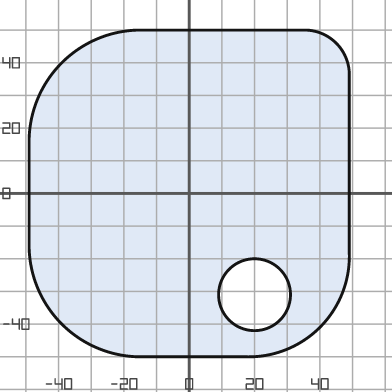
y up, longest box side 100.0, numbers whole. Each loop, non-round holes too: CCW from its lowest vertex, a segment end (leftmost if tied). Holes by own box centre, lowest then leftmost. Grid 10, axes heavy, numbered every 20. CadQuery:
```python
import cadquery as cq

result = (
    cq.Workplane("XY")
    .moveTo(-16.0, -50.0)
    .lineTo(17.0, -50.0)
    .threePointArc((40.0, -41.0), (49.0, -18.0))
    .lineTo(49.0, 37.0)
    .threePointArc((45.0, 46.0), (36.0, 50.0))
    .lineTo(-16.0, 50.0)
    .threePointArc((-39.0, 40.0), (-49.0, 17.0))
    .lineTo(-49.0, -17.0)
    .threePointArc((-39.0, -40.0), (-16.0, -50.0))
    .close()
    .moveTo(20.0, -31.0)
    .circle(11.0)
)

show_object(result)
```